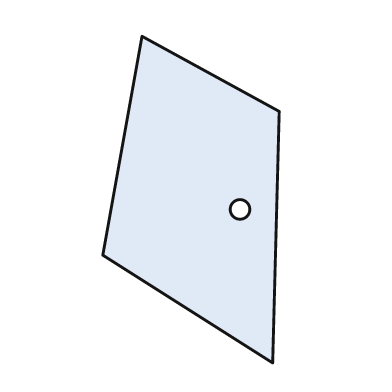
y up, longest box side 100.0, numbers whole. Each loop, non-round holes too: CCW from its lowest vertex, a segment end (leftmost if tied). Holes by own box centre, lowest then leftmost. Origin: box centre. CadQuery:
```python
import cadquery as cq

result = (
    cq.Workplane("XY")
    .moveTo(25.0, -50.0)
    .lineTo(27.0, 27.0)
    .lineTo(-15.0, 50.0)
    .lineTo(-27.0, -17.0)
    .close()
    .moveTo(15.0, -3.0)
    .circle(3.0)
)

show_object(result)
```